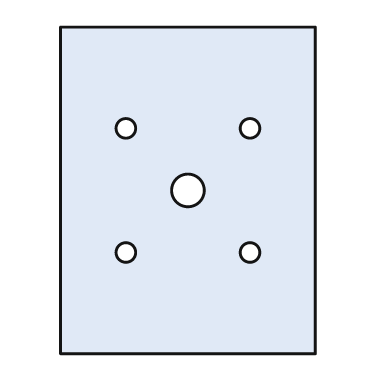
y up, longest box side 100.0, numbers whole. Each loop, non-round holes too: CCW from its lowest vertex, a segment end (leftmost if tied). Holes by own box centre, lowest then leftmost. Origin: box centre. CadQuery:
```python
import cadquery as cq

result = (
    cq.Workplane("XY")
    .moveTo(-39.0, -50.0)
    .lineTo(39.0, -50.0)
    .lineTo(39.0, 50.0)
    .lineTo(-39.0, 50.0)
    .close()
    .moveTo(-19.0, -19.0)
    .circle(3.0)
    .moveTo(19.0, -19.0)
    .circle(3.0)
    .moveTo(0.0, 0.0)
    .circle(5.0)
    .moveTo(-19.0, 19.0)
    .circle(3.0)
    .moveTo(19.0, 19.0)
    .circle(3.0)
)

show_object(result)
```